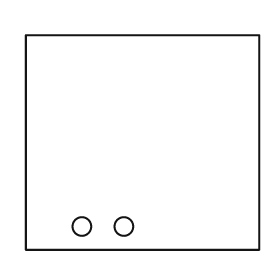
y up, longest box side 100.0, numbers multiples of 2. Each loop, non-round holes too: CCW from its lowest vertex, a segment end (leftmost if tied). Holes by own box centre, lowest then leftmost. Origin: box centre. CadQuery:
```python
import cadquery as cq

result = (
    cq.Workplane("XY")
    .moveTo(-50.0, -46.0)
    .lineTo(50.0, -46.0)
    .lineTo(50.0, 46.0)
    .lineTo(-50.0, 46.0)
    .close()
    .moveTo(-26.0, -36.0)
    .circle(4.0)
    .moveTo(-8.0, -36.0)
    .circle(4.0)
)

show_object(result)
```